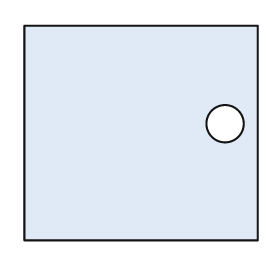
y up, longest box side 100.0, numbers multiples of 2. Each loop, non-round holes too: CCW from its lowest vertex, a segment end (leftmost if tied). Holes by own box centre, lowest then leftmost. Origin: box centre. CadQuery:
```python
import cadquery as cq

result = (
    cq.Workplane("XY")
    .moveTo(-50.0, -46.0)
    .lineTo(50.0, -46.0)
    .lineTo(50.0, 46.0)
    .lineTo(-50.0, 46.0)
    .close()
    .moveTo(36.0, 4.0)
    .circle(8.0)
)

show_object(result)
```